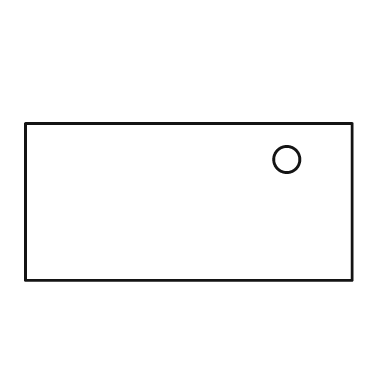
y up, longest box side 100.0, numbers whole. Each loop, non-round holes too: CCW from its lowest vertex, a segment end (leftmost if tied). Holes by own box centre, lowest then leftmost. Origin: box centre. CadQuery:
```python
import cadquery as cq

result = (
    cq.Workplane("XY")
    .moveTo(-50.0, -24.0)
    .lineTo(50.0, -24.0)
    .lineTo(50.0, 24.0)
    .lineTo(-50.0, 24.0)
    .close()
    .moveTo(30.0, 13.0)
    .circle(4.0)
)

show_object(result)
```